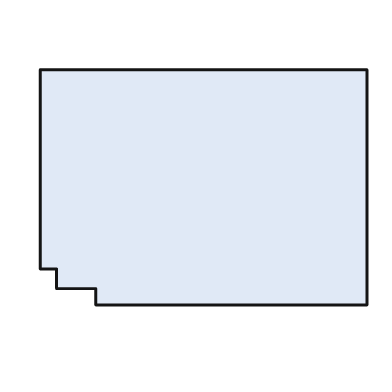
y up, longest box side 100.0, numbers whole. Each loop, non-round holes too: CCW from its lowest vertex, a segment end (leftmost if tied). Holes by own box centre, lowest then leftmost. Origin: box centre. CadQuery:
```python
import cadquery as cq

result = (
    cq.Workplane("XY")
    .moveTo(-33.0, -36.0)
    .lineTo(50.0, -36.0)
    .lineTo(50.0, 36.0)
    .lineTo(-50.0, 36.0)
    .lineTo(-50.0, -25.0)
    .lineTo(-45.0, -25.0)
    .lineTo(-45.0, -31.0)
    .lineTo(-33.0, -31.0)
    .close()
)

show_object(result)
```